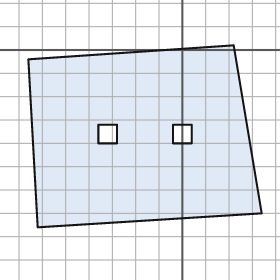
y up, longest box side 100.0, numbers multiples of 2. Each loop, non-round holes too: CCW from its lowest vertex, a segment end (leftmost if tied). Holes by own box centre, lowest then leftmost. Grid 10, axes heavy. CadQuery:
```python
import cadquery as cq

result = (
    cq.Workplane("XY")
    .moveTo(-62.0, -76.0)
    .lineTo(34.0, -70.0)
    .lineTo(22.0, 2.0)
    .lineTo(-66.0, -4.0)
    .close()
    .moveTo(-36.0, -40.0)
    .lineTo(-28.0, -40.0)
    .lineTo(-28.0, -32.0)
    .lineTo(-36.0, -32.0)
    .close()
    .moveTo(-4.0, -40.0)
    .lineTo(4.0, -40.0)
    .lineTo(4.0, -32.0)
    .lineTo(-4.0, -32.0)
    .close()
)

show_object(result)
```